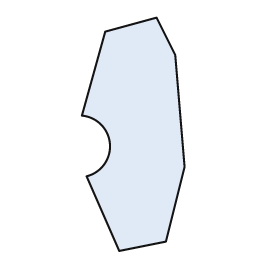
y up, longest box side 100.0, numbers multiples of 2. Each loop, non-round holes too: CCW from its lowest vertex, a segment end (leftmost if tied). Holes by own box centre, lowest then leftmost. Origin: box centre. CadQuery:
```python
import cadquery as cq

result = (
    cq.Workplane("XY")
    .moveTo(-6.0, -50.0)
    .lineTo(14.0, -46.0)
    .lineTo(22.0, -14.0)
    .lineTo(18.0, 34.0)
    .lineTo(10.0, 50.0)
    .lineTo(-12.0, 44.0)
    .lineTo(-22.0, 8.0)
    .threePointArc((-10.0, -4.0), (-20.0, -18.0))
    .close()
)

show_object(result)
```